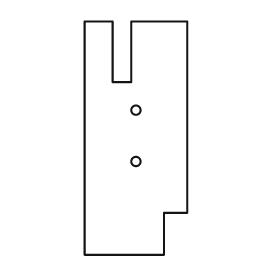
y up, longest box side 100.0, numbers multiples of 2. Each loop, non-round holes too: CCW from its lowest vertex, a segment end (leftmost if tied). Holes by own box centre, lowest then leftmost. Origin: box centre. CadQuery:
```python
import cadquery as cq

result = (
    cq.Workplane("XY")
    .moveTo(-22.0, -50.0)
    .lineTo(12.0, -50.0)
    .lineTo(12.0, -32.0)
    .lineTo(22.0, -32.0)
    .lineTo(22.0, 50.0)
    .lineTo(-2.0, 50.0)
    .lineTo(-2.0, 24.0)
    .lineTo(-10.0, 24.0)
    .lineTo(-10.0, 50.0)
    .lineTo(-22.0, 50.0)
    .close()
    .moveTo(0.0, -10.0)
    .circle(2.0)
    .moveTo(0.0, 12.0)
    .circle(2.0)
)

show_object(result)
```